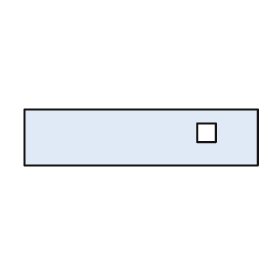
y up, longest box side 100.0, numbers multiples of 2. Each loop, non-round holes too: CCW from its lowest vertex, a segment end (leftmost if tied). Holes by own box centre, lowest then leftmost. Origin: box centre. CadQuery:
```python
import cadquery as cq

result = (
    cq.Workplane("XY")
    .moveTo(-50.0, -12.0)
    .lineTo(50.0, -12.0)
    .lineTo(50.0, 12.0)
    .lineTo(-50.0, 12.0)
    .close()
    .moveTo(24.0, -2.0)
    .lineTo(32.0, -2.0)
    .lineTo(32.0, 6.0)
    .lineTo(24.0, 6.0)
    .close()
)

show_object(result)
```